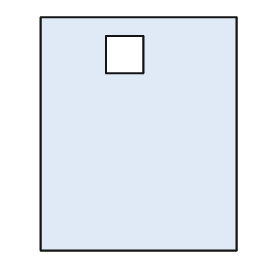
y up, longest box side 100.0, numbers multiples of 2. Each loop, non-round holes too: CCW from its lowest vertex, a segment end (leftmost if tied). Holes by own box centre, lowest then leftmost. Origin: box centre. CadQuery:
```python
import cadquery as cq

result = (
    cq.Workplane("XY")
    .moveTo(-42.0, -50.0)
    .lineTo(42.0, -50.0)
    .lineTo(42.0, 50.0)
    .lineTo(-42.0, 50.0)
    .close()
    .moveTo(-14.0, 26.0)
    .lineTo(2.0, 26.0)
    .lineTo(2.0, 42.0)
    .lineTo(-14.0, 42.0)
    .close()
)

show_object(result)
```